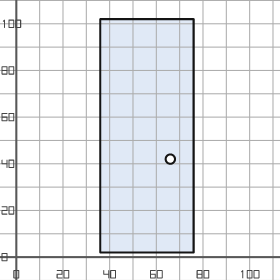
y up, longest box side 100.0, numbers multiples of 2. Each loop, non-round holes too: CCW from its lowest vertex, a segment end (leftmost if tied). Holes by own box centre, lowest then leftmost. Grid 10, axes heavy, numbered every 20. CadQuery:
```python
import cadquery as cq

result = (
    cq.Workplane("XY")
    .moveTo(36.0, 2.0)
    .lineTo(76.0, 2.0)
    .lineTo(76.0, 102.0)
    .lineTo(36.0, 102.0)
    .close()
    .moveTo(66.0, 42.0)
    .circle(2.0)
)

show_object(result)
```